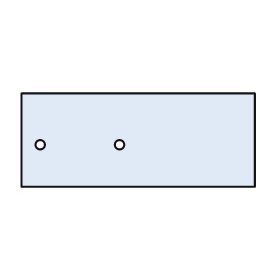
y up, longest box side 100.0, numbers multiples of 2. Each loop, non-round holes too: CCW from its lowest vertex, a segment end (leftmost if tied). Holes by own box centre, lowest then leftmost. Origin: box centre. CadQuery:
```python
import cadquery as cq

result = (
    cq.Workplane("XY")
    .moveTo(-50.0, -20.0)
    .lineTo(50.0, -20.0)
    .lineTo(50.0, 20.0)
    .lineTo(-50.0, 20.0)
    .close()
    .moveTo(-42.0, -2.0)
    .circle(2.0)
    .moveTo(-8.0, -2.0)
    .circle(2.0)
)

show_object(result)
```